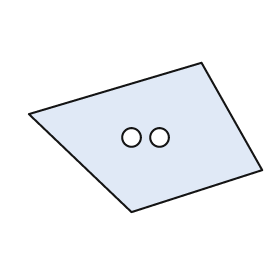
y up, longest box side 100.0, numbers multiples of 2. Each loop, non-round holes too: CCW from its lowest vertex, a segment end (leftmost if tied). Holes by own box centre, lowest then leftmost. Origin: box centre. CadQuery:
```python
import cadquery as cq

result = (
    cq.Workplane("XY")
    .moveTo(-6.0, -32.0)
    .lineTo(50.0, -14.0)
    .lineTo(24.0, 32.0)
    .lineTo(-50.0, 10.0)
    .close()
    .moveTo(-6.0, 0.0)
    .circle(4.0)
    .moveTo(6.0, 0.0)
    .circle(4.0)
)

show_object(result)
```